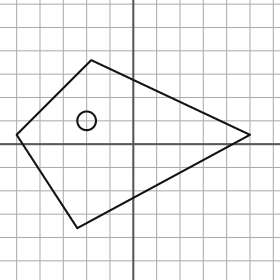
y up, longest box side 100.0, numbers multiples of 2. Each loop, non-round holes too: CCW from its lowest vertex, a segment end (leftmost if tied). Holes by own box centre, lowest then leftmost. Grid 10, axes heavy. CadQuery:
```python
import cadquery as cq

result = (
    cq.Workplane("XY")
    .moveTo(-24.0, -36.0)
    .lineTo(50.0, 4.0)
    .lineTo(-18.0, 36.0)
    .lineTo(-50.0, 4.0)
    .close()
    .moveTo(-20.0, 10.0)
    .circle(4.0)
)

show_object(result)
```